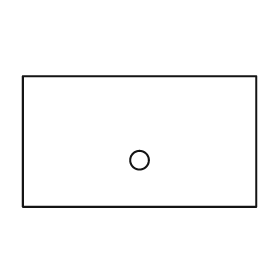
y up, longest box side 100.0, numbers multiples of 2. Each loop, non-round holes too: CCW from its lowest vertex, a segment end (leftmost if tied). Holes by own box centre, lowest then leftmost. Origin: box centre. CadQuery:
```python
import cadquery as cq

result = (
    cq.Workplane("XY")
    .moveTo(-50.0, -28.0)
    .lineTo(50.0, -28.0)
    .lineTo(50.0, 28.0)
    .lineTo(-50.0, 28.0)
    .close()
    .moveTo(0.0, -8.0)
    .circle(4.0)
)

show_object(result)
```